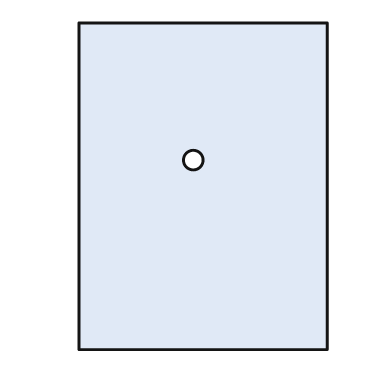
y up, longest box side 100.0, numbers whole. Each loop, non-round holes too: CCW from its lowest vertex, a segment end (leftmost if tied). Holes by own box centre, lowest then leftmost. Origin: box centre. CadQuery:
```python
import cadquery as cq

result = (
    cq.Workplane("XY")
    .moveTo(-38.0, -50.0)
    .lineTo(38.0, -50.0)
    .lineTo(38.0, 50.0)
    .lineTo(-38.0, 50.0)
    .close()
    .moveTo(-3.0, 8.0)
    .circle(3.0)
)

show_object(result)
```